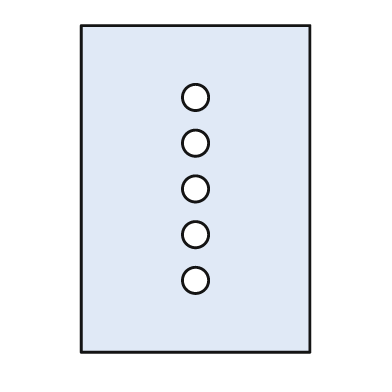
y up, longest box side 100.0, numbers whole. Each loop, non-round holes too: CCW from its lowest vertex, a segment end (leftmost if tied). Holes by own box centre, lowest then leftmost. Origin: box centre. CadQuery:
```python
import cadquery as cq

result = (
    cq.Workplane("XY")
    .moveTo(-35.0, -50.0)
    .lineTo(35.0, -50.0)
    .lineTo(35.0, 50.0)
    .lineTo(-35.0, 50.0)
    .close()
    .moveTo(0.0, -28.0)
    .circle(4.0)
    .moveTo(0.0, -14.0)
    .circle(4.0)
    .moveTo(0.0, 0.0)
    .circle(4.0)
    .moveTo(0.0, 14.0)
    .circle(4.0)
    .moveTo(0.0, 28.0)
    .circle(4.0)
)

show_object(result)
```